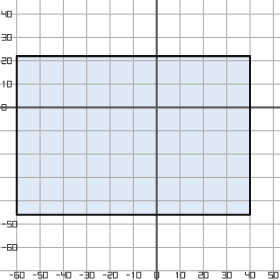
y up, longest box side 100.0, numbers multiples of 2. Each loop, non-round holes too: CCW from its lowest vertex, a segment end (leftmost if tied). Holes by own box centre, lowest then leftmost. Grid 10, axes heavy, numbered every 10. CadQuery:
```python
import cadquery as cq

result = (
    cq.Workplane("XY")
    .moveTo(-60.0, -46.0)
    .lineTo(40.0, -46.0)
    .lineTo(40.0, 22.0)
    .lineTo(-60.0, 22.0)
    .close()
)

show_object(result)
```